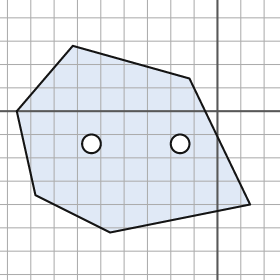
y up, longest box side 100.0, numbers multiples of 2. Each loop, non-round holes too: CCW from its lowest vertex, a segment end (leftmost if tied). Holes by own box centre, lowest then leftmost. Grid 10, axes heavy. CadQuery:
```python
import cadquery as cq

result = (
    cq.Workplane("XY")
    .moveTo(-46.0, -52.0)
    .lineTo(14.0, -40.0)
    .lineTo(-12.0, 14.0)
    .lineTo(-62.0, 28.0)
    .lineTo(-86.0, 0.0)
    .lineTo(-78.0, -36.0)
    .close()
    .moveTo(-54.0, -14.0)
    .circle(4.0)
    .moveTo(-16.0, -14.0)
    .circle(4.0)
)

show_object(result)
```